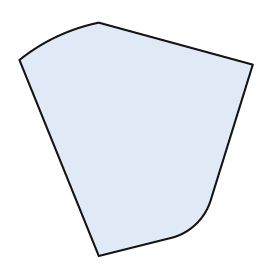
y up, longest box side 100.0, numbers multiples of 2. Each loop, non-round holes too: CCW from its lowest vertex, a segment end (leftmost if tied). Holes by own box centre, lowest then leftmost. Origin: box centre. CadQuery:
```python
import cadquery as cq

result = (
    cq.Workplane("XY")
    .moveTo(-16.0, -50.0)
    .lineTo(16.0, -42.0)
    .threePointArc((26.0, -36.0), (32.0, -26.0))
    .lineTo(50.0, 32.0)
    .lineTo(-16.0, 50.0)
    .threePointArc((-34.0, 44.0), (-50.0, 34.0))
    .close()
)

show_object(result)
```